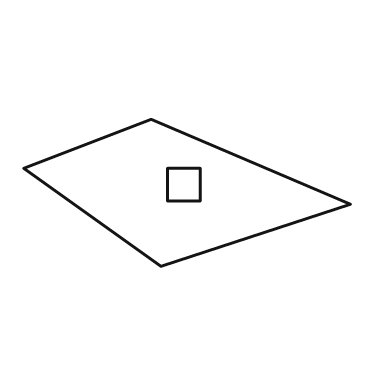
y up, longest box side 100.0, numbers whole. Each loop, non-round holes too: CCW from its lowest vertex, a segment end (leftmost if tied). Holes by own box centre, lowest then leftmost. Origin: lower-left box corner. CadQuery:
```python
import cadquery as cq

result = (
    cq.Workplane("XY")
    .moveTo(42.0, 0.0)
    .lineTo(100.0, 19.0)
    .lineTo(39.0, 45.0)
    .lineTo(0.0, 30.0)
    .close()
    .moveTo(44.0, 20.0)
    .lineTo(54.0, 20.0)
    .lineTo(54.0, 30.0)
    .lineTo(44.0, 30.0)
    .close()
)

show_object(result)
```